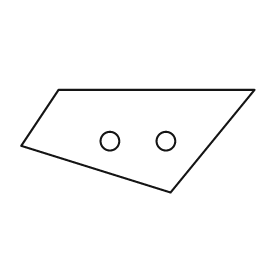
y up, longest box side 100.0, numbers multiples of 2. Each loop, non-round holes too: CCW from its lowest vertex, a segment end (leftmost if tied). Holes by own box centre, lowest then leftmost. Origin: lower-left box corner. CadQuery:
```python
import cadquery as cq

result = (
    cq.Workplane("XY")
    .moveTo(64.0, 0.0)
    .lineTo(100.0, 44.0)
    .lineTo(16.0, 44.0)
    .lineTo(0.0, 20.0)
    .close()
    .moveTo(38.0, 22.0)
    .circle(4.0)
    .moveTo(62.0, 22.0)
    .circle(4.0)
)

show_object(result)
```